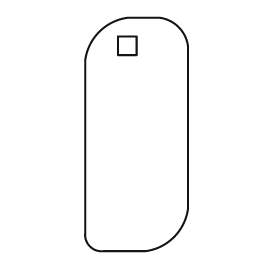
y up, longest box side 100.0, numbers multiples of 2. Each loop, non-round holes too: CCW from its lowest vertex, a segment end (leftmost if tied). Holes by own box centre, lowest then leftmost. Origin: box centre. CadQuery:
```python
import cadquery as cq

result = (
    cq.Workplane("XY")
    .moveTo(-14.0, -50.0)
    .lineTo(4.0, -50.0)
    .threePointArc((16.0, -44.0), (22.0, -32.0))
    .lineTo(22.0, 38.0)
    .threePointArc((18.0, 46.0), (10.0, 50.0))
    .lineTo(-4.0, 50.0)
    .threePointArc((-16.0, 44.0), (-22.0, 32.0))
    .lineTo(-22.0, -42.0)
    .threePointArc((-20.0, -48.0), (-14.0, -50.0))
    .close()
    .moveTo(-8.0, 34.0)
    .lineTo(0.0, 34.0)
    .lineTo(0.0, 42.0)
    .lineTo(-8.0, 42.0)
    .close()
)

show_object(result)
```